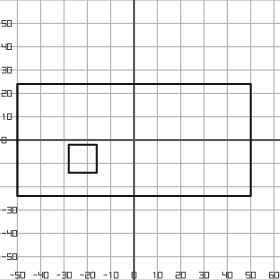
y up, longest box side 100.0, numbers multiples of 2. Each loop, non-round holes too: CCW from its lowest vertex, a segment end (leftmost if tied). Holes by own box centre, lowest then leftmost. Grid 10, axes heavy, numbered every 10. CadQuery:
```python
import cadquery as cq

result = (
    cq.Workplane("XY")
    .moveTo(-50.0, -24.0)
    .lineTo(50.0, -24.0)
    .lineTo(50.0, 24.0)
    .lineTo(-50.0, 24.0)
    .close()
    .moveTo(-28.0, -14.0)
    .lineTo(-16.0, -14.0)
    .lineTo(-16.0, -2.0)
    .lineTo(-28.0, -2.0)
    .close()
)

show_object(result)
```